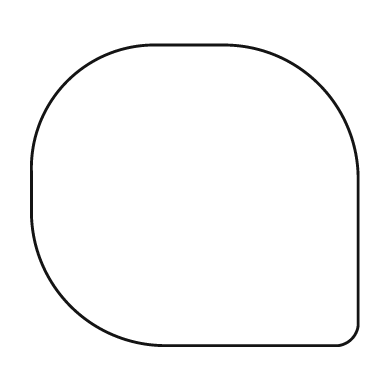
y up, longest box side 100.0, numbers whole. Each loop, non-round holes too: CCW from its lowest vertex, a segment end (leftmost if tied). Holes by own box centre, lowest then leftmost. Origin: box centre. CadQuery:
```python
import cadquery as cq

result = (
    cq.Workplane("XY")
    .moveTo(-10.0, -46.0)
    .lineTo(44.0, -46.0)
    .threePointArc((48.0, -44.0), (50.0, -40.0))
    .lineTo(50.0, 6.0)
    .threePointArc((38.0, 34.0), (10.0, 46.0))
    .lineTo(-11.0, 46.0)
    .threePointArc((-39.0, 35.0), (-50.0, 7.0))
    .lineTo(-50.0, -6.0)
    .threePointArc((-38.0, -34.0), (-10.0, -46.0))
    .close()
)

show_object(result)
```